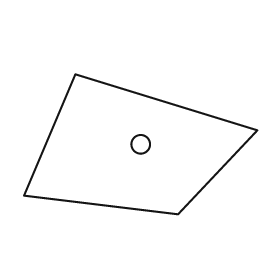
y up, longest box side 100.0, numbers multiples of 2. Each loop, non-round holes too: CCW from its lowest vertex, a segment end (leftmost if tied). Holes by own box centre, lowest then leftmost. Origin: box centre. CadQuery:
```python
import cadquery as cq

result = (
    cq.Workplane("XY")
    .moveTo(16.0, -30.0)
    .lineTo(50.0, 6.0)
    .lineTo(-28.0, 30.0)
    .lineTo(-50.0, -22.0)
    .close()
    .moveTo(0.0, 0.0)
    .circle(4.0)
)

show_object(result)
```